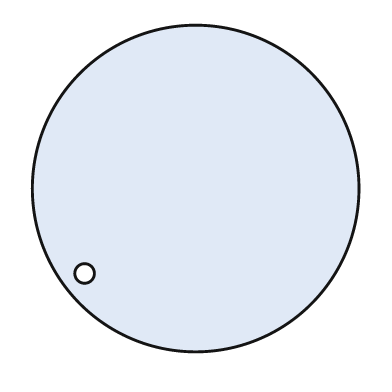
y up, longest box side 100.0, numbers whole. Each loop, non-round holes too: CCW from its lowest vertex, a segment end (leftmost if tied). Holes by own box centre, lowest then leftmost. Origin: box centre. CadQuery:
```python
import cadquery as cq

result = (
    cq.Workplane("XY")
    .moveTo(0.0, 0.0)
    .circle(50.0)
    .moveTo(-34.0, -26.0)
    .circle(3.0)
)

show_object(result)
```